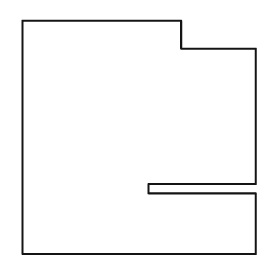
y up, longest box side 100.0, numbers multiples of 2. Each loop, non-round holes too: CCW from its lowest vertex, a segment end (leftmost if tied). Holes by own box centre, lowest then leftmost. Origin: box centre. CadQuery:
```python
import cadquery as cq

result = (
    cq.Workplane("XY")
    .moveTo(-50.0, -50.0)
    .lineTo(50.0, -50.0)
    .lineTo(50.0, -24.0)
    .lineTo(4.0, -24.0)
    .lineTo(4.0, -20.0)
    .lineTo(50.0, -20.0)
    .lineTo(50.0, 38.0)
    .lineTo(18.0, 38.0)
    .lineTo(18.0, 50.0)
    .lineTo(-50.0, 50.0)
    .close()
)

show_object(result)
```